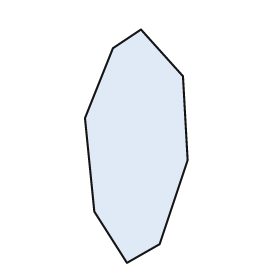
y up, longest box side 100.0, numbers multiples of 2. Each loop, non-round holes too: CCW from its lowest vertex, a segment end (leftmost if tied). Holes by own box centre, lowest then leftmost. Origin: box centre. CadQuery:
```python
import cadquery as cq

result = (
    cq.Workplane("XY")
    .moveTo(-4.0, -50.0)
    .lineTo(10.0, -42.0)
    .lineTo(22.0, -6.0)
    .lineTo(20.0, 30.0)
    .lineTo(2.0, 50.0)
    .lineTo(-10.0, 42.0)
    .lineTo(-22.0, 12.0)
    .lineTo(-18.0, -28.0)
    .close()
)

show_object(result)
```